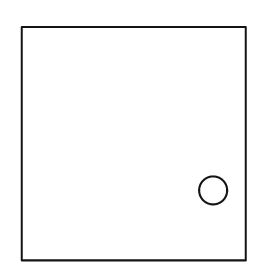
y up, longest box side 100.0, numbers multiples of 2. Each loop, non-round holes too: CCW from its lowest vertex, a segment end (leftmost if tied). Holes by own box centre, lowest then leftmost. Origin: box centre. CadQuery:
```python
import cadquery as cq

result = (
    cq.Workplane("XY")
    .moveTo(-48.0, -50.0)
    .lineTo(48.0, -50.0)
    .lineTo(48.0, 50.0)
    .lineTo(-48.0, 50.0)
    .close()
    .moveTo(34.0, -20.0)
    .circle(6.0)
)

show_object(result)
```